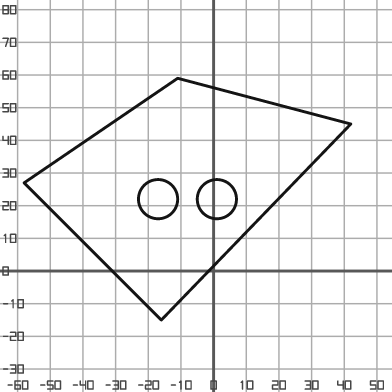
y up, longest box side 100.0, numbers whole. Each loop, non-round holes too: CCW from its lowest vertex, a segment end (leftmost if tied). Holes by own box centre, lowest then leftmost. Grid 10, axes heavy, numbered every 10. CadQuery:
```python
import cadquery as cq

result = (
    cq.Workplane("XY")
    .moveTo(-16.0, -15.0)
    .lineTo(42.0, 45.0)
    .lineTo(-11.0, 59.0)
    .lineTo(-58.0, 27.0)
    .close()
    .moveTo(-17.0, 22.0)
    .circle(6.0)
    .moveTo(1.0, 22.0)
    .circle(6.0)
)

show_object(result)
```